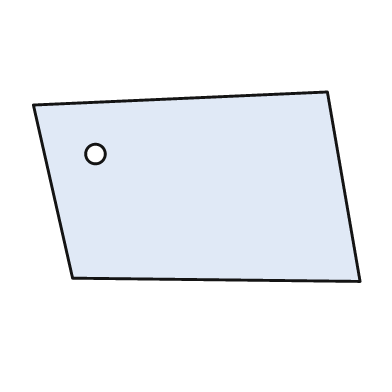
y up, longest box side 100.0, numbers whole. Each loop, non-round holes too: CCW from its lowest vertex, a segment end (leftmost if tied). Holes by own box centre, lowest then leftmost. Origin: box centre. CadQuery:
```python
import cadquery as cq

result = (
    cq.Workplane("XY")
    .moveTo(50.0, -29.0)
    .lineTo(40.0, 29.0)
    .lineTo(-50.0, 25.0)
    .lineTo(-38.0, -28.0)
    .close()
    .moveTo(-31.0, 10.0)
    .circle(3.0)
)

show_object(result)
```